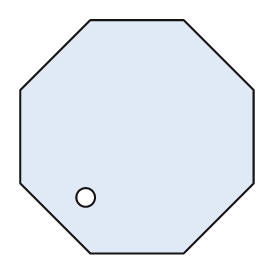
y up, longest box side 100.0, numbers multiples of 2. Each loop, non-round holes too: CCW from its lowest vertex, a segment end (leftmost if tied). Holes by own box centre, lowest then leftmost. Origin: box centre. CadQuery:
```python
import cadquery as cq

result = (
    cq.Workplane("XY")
    .moveTo(-20.0, -50.0)
    .lineTo(20.0, -50.0)
    .lineTo(50.0, -20.0)
    .lineTo(50.0, 20.0)
    .lineTo(20.0, 50.0)
    .lineTo(-20.0, 50.0)
    .lineTo(-50.0, 20.0)
    .lineTo(-50.0, -20.0)
    .close()
    .moveTo(-22.0, -26.0)
    .circle(4.0)
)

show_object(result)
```